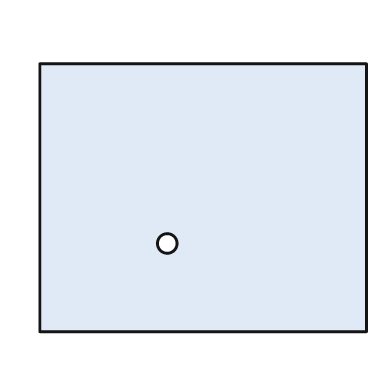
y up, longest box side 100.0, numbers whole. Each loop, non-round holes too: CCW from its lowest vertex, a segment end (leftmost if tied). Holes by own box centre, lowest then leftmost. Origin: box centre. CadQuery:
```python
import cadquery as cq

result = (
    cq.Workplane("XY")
    .moveTo(-50.0, -41.0)
    .lineTo(50.0, -41.0)
    .lineTo(50.0, 41.0)
    .lineTo(-50.0, 41.0)
    .close()
    .moveTo(-11.0, -14.0)
    .circle(3.0)
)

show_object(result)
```